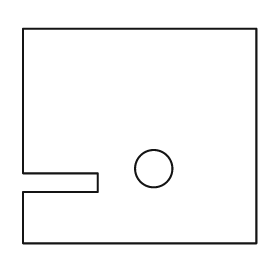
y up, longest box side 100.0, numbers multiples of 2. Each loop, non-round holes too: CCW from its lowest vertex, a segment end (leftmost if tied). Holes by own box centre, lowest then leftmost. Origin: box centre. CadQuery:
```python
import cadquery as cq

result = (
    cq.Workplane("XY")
    .moveTo(-50.0, -46.0)
    .lineTo(50.0, -46.0)
    .lineTo(50.0, 46.0)
    .lineTo(-50.0, 46.0)
    .lineTo(-50.0, -16.0)
    .lineTo(-18.0, -16.0)
    .lineTo(-18.0, -24.0)
    .lineTo(-50.0, -24.0)
    .close()
    .moveTo(6.0, -14.0)
    .circle(8.0)
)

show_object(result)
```